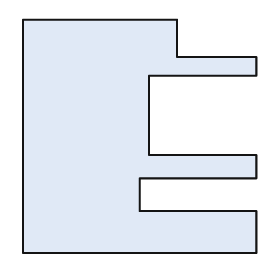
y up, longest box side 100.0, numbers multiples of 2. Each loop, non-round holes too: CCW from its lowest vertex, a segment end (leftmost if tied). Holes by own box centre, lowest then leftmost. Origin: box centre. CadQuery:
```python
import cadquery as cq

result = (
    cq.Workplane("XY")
    .moveTo(-50.0, -50.0)
    .lineTo(50.0, -50.0)
    .lineTo(50.0, -32.0)
    .lineTo(0.0, -32.0)
    .lineTo(0.0, -18.0)
    .lineTo(50.0, -18.0)
    .lineTo(50.0, -8.0)
    .lineTo(4.0, -8.0)
    .lineTo(4.0, 26.0)
    .lineTo(50.0, 26.0)
    .lineTo(50.0, 34.0)
    .lineTo(16.0, 34.0)
    .lineTo(16.0, 50.0)
    .lineTo(-50.0, 50.0)
    .close()
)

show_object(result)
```